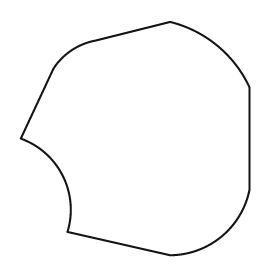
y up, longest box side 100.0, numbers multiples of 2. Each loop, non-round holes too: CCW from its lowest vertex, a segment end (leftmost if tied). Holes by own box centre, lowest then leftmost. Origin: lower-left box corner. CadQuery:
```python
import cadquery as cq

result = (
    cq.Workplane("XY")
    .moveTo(64.0, 0.0)
    .threePointArc((86.0, 8.0), (98.0, 28.0))
    .lineTo(98.0, 72.0)
    .threePointArc((84.0, 90.0), (64.0, 100.0))
    .lineTo(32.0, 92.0)
    .threePointArc((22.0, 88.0), (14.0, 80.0))
    .lineTo(0.0, 50.0)
    .threePointArc((18.0, 34.0), (20.0, 10.0))
    .close()
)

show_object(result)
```